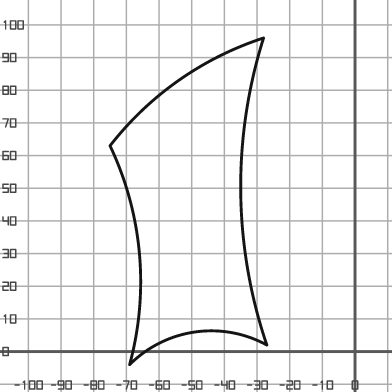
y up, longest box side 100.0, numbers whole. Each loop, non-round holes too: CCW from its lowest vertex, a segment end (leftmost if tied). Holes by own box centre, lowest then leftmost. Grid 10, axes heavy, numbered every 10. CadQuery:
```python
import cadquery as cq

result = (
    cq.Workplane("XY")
    .moveTo(-69.0, -4.0)
    .threePointArc((-49.0, 6.0), (-27.0, 2.0))
    .threePointArc((-35.0, 49.0), (-28.0, 96.0))
    .threePointArc((-54.0, 83.0), (-75.0, 63.0))
    .threePointArc((-66.0, 30.0), (-69.0, -4.0))
    .close()
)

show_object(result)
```